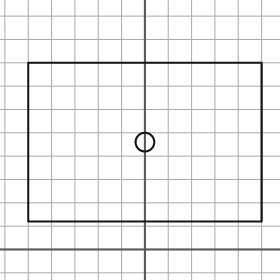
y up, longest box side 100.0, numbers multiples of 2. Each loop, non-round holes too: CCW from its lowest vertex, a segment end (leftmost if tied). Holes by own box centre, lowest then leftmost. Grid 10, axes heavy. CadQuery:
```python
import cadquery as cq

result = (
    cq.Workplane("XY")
    .moveTo(-50.0, 12.0)
    .lineTo(50.0, 12.0)
    .lineTo(50.0, 80.0)
    .lineTo(-50.0, 80.0)
    .close()
    .moveTo(0.0, 46.0)
    .circle(4.0)
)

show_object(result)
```